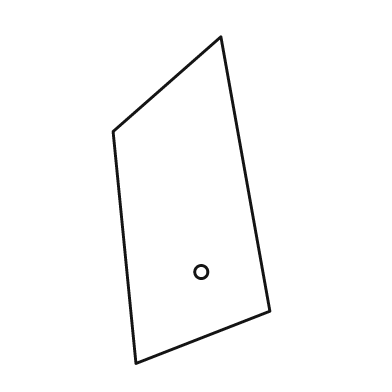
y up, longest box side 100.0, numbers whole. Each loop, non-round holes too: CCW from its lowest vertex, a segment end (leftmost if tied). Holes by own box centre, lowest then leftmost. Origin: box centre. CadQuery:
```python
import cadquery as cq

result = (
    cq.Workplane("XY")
    .moveTo(-17.0, -50.0)
    .lineTo(24.0, -34.0)
    .lineTo(9.0, 50.0)
    .lineTo(-24.0, 21.0)
    .close()
    .moveTo(3.0, -22.0)
    .circle(2.0)
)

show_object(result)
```